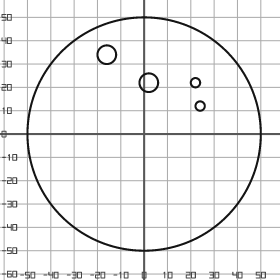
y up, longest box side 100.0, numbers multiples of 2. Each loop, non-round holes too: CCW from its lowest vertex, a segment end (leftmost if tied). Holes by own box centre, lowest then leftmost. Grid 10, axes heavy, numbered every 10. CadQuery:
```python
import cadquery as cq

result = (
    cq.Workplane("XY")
    .moveTo(0.0, 0.0)
    .circle(50.0)
    .moveTo(24.0, 12.0)
    .circle(2.0)
    .moveTo(2.0, 22.0)
    .circle(4.0)
    .moveTo(22.0, 22.0)
    .circle(2.0)
    .moveTo(-16.0, 34.0)
    .circle(4.0)
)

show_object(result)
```